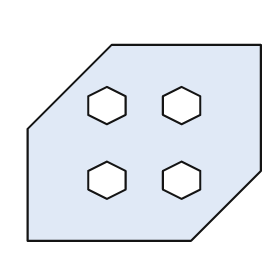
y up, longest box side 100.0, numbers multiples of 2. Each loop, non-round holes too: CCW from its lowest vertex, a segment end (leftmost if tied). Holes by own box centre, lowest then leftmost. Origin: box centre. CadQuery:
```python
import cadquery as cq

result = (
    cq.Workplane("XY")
    .moveTo(-50.0, -42.0)
    .lineTo(20.0, -42.0)
    .lineTo(50.0, -12.0)
    .lineTo(50.0, 42.0)
    .lineTo(-14.0, 42.0)
    .lineTo(-50.0, 6.0)
    .close()
    .moveTo(-16.0, -24.0)
    .lineTo(-8.0, -20.0)
    .lineTo(-8.0, -12.0)
    .lineTo(-16.0, -8.0)
    .lineTo(-24.0, -12.0)
    .lineTo(-24.0, -20.0)
    .close()
    .moveTo(16.0, -24.0)
    .lineTo(24.0, -20.0)
    .lineTo(24.0, -12.0)
    .lineTo(16.0, -8.0)
    .lineTo(8.0, -12.0)
    .lineTo(8.0, -20.0)
    .close()
    .moveTo(-16.0, 8.0)
    .lineTo(-8.0, 12.0)
    .lineTo(-8.0, 20.0)
    .lineTo(-16.0, 24.0)
    .lineTo(-24.0, 20.0)
    .lineTo(-24.0, 12.0)
    .close()
    .moveTo(16.0, 8.0)
    .lineTo(24.0, 12.0)
    .lineTo(24.0, 20.0)
    .lineTo(16.0, 24.0)
    .lineTo(8.0, 20.0)
    .lineTo(8.0, 12.0)
    .close()
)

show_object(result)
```